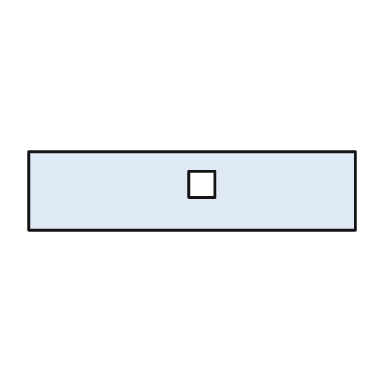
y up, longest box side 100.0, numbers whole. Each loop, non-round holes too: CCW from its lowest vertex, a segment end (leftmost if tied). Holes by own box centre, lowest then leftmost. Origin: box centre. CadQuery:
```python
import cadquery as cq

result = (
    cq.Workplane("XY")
    .moveTo(-50.0, -12.0)
    .lineTo(50.0, -12.0)
    .lineTo(50.0, 12.0)
    .lineTo(-50.0, 12.0)
    .close()
    .moveTo(-1.0, -2.0)
    .lineTo(7.0, -2.0)
    .lineTo(7.0, 6.0)
    .lineTo(-1.0, 6.0)
    .close()
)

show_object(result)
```